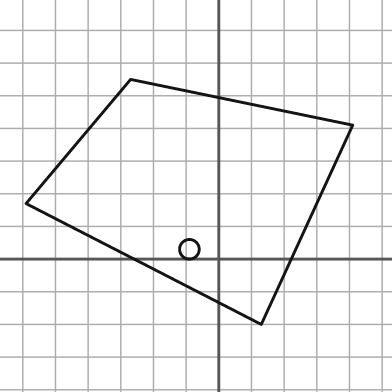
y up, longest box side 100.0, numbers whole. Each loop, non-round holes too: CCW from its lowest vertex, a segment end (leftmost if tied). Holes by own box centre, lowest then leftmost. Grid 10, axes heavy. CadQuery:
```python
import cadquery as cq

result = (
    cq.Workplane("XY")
    .moveTo(13.0, -20.0)
    .lineTo(41.0, 41.0)
    .lineTo(-27.0, 55.0)
    .lineTo(-59.0, 17.0)
    .close()
    .moveTo(-9.0, 3.0)
    .circle(3.0)
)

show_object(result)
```